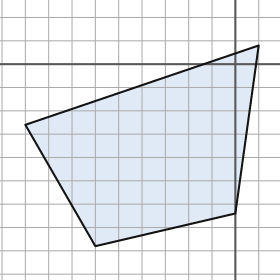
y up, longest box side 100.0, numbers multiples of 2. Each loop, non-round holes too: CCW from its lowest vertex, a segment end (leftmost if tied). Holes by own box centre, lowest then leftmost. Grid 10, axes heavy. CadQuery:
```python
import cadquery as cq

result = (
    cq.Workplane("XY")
    .moveTo(-60.0, -78.0)
    .lineTo(0.0, -64.0)
    .lineTo(10.0, 8.0)
    .lineTo(-90.0, -26.0)
    .close()
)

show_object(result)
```